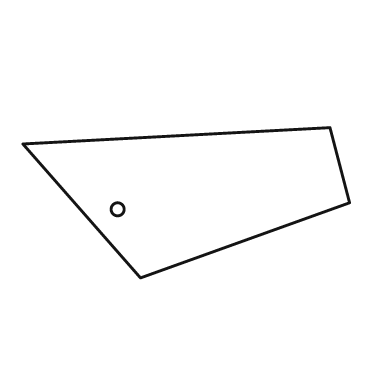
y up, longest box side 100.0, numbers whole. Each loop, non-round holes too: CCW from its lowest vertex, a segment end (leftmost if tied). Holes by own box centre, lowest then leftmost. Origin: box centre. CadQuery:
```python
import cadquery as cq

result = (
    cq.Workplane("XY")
    .moveTo(-14.0, -23.0)
    .lineTo(50.0, 0.0)
    .lineTo(44.0, 23.0)
    .lineTo(-50.0, 18.0)
    .close()
    .moveTo(-21.0, -2.0)
    .circle(2.0)
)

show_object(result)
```